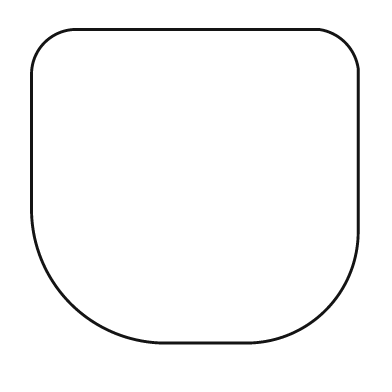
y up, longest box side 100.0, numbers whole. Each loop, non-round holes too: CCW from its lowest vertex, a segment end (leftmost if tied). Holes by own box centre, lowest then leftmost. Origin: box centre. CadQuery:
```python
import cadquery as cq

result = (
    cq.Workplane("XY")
    .moveTo(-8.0, -48.0)
    .lineTo(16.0, -48.0)
    .threePointArc((40.0, -38.0), (50.0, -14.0))
    .lineTo(50.0, 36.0)
    .threePointArc((46.0, 44.0), (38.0, 48.0))
    .lineTo(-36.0, 48.0)
    .threePointArc((-46.0, 44.0), (-50.0, 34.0))
    .lineTo(-50.0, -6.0)
    .threePointArc((-38.0, -36.0), (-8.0, -48.0))
    .close()
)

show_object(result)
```